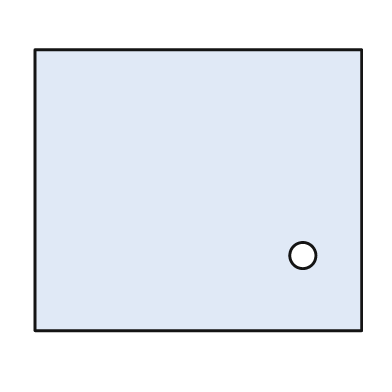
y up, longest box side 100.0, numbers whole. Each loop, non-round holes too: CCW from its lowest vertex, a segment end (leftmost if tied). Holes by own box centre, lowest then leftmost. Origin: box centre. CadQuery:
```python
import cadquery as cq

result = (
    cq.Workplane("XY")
    .moveTo(-50.0, -43.0)
    .lineTo(50.0, -43.0)
    .lineTo(50.0, 43.0)
    .lineTo(-50.0, 43.0)
    .close()
    .moveTo(32.0, -20.0)
    .circle(4.0)
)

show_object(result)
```